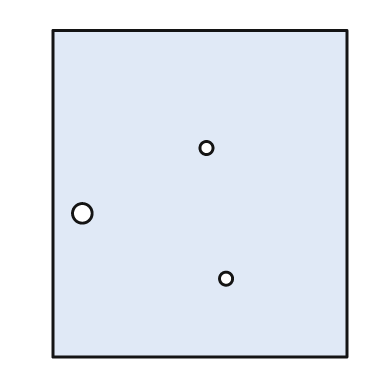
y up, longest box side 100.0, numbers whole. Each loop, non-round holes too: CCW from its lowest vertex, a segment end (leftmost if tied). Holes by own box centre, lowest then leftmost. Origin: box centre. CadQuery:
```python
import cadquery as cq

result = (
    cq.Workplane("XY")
    .moveTo(-45.0, -50.0)
    .lineTo(45.0, -50.0)
    .lineTo(45.0, 50.0)
    .lineTo(-45.0, 50.0)
    .close()
    .moveTo(8.0, -26.0)
    .circle(2.0)
    .moveTo(-36.0, -6.0)
    .circle(3.0)
    .moveTo(2.0, 14.0)
    .circle(2.0)
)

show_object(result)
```